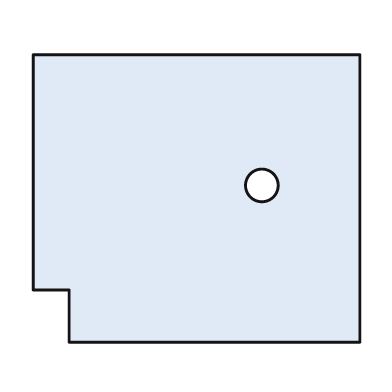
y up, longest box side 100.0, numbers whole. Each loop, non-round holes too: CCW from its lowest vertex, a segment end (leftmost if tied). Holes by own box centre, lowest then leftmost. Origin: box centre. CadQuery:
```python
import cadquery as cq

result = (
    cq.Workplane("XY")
    .moveTo(-39.0, -44.0)
    .lineTo(50.0, -44.0)
    .lineTo(50.0, 44.0)
    .lineTo(-50.0, 44.0)
    .lineTo(-50.0, -28.0)
    .lineTo(-39.0, -28.0)
    .close()
    .moveTo(20.0, 4.0)
    .circle(5.0)
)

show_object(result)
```